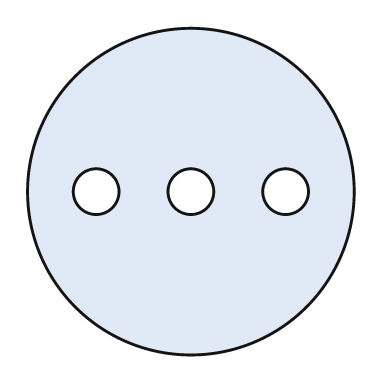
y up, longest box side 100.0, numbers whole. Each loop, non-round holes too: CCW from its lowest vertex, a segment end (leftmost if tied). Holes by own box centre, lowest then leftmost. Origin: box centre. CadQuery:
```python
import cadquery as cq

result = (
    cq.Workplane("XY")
    .moveTo(0.0, 0.0)
    .circle(50.0)
    .moveTo(-29.0, 0.0)
    .circle(7.0)
    .moveTo(0.0, 0.0)
    .circle(7.0)
    .moveTo(29.0, 0.0)
    .circle(7.0)
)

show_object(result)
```